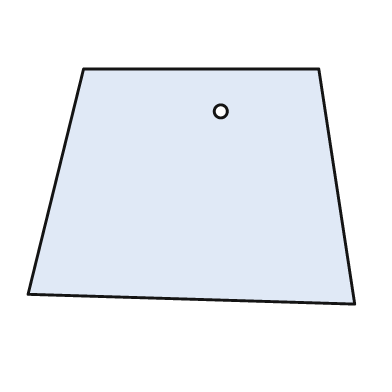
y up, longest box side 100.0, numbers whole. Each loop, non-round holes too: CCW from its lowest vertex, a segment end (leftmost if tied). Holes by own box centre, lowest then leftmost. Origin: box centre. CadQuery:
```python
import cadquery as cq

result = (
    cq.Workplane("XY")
    .moveTo(50.0, -36.0)
    .lineTo(39.0, 36.0)
    .lineTo(-33.0, 36.0)
    .lineTo(-50.0, -33.0)
    .close()
    .moveTo(9.0, 23.0)
    .circle(2.0)
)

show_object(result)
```